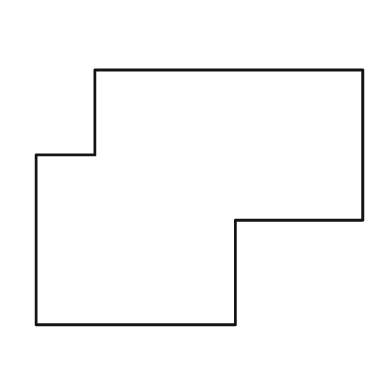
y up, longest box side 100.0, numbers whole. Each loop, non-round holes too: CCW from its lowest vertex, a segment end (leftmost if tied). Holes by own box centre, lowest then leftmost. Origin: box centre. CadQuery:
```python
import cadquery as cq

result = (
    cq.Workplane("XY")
    .moveTo(-50.0, -39.0)
    .lineTo(11.0, -39.0)
    .lineTo(11.0, -7.0)
    .lineTo(50.0, -7.0)
    .lineTo(50.0, 39.0)
    .lineTo(-32.0, 39.0)
    .lineTo(-32.0, 13.0)
    .lineTo(-50.0, 13.0)
    .close()
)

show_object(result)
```